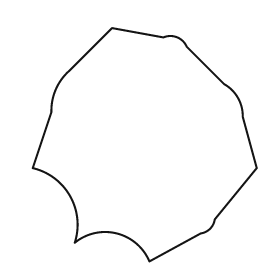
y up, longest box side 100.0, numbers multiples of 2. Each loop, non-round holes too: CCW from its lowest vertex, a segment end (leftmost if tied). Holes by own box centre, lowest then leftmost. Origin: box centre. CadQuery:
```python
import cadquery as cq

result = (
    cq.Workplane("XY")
    .moveTo(2.0, -50.0)
    .lineTo(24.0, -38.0)
    .threePointArc((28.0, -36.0), (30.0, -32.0))
    .lineTo(48.0, -10.0)
    .lineTo(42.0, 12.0)
    .threePointArc((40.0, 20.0), (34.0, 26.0))
    .lineTo(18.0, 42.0)
    .threePointArc((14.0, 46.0), (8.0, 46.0))
    .lineTo(-14.0, 50.0)
    .lineTo(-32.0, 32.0)
    .threePointArc((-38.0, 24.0), (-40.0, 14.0))
    .lineTo(-48.0, -10.0)
    .threePointArc((-32.0, -22.0), (-30.0, -42.0))
    .threePointArc((-12.0, -38.0), (2.0, -50.0))
    .close()
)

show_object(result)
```